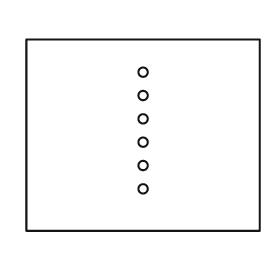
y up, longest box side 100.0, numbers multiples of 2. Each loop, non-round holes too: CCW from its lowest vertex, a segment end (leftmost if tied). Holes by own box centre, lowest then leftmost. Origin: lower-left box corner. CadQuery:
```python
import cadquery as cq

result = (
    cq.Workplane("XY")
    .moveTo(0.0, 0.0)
    .lineTo(100.0, 0.0)
    .lineTo(100.0, 82.0)
    .lineTo(0.0, 82.0)
    .close()
    .moveTo(50.0, 18.0)
    .circle(2.0)
    .moveTo(50.0, 28.0)
    .circle(2.0)
    .moveTo(50.0, 38.0)
    .circle(2.0)
    .moveTo(50.0, 48.0)
    .circle(2.0)
    .moveTo(50.0, 58.0)
    .circle(2.0)
    .moveTo(50.0, 68.0)
    .circle(2.0)
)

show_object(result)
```